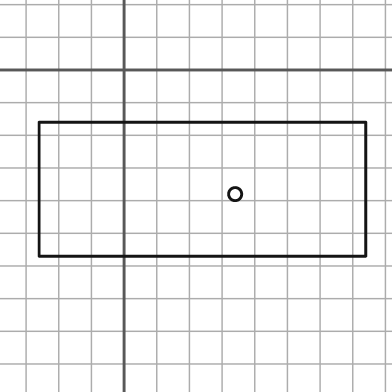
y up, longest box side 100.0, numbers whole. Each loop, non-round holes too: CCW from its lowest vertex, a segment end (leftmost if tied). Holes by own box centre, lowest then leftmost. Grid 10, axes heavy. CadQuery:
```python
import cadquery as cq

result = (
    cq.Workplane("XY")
    .moveTo(-26.0, -57.0)
    .lineTo(74.0, -57.0)
    .lineTo(74.0, -16.0)
    .lineTo(-26.0, -16.0)
    .close()
    .moveTo(34.0, -38.0)
    .circle(2.0)
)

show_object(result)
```